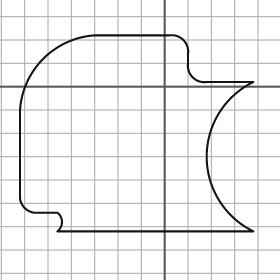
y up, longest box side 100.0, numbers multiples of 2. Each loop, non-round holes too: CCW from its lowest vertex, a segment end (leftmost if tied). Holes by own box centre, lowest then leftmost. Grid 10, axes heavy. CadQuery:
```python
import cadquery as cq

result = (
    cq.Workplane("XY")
    .moveTo(-46.0, -62.0)
    .lineTo(38.0, -62.0)
    .threePointArc((18.0, -30.0), (38.0, 2.0))
    .lineTo(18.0, 2.0)
    .threePointArc((12.0, 4.0), (10.0, 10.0))
    .lineTo(10.0, 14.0)
    .threePointArc((8.0, 20.0), (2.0, 22.0))
    .lineTo(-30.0, 22.0)
    .threePointArc((-52.0, 12.0), (-62.0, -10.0))
    .lineTo(-62.0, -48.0)
    .threePointArc((-60.0, -52.0), (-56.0, -54.0))
    .lineTo(-46.0, -54.0)
    .threePointArc((-44.0, -58.0), (-46.0, -62.0))
    .close()
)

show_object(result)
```